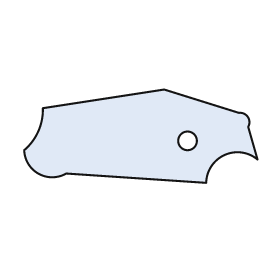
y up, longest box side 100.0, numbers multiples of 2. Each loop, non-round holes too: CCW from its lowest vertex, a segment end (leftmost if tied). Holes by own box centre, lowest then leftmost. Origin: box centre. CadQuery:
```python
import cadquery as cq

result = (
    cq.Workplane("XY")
    .moveTo(28.0, -20.0)
    .threePointArc((36.0, -8.0), (50.0, -10.0))
    .lineTo(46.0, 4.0)
    .threePointArc((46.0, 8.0), (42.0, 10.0))
    .lineTo(10.0, 20.0)
    .lineTo(-42.0, 12.0)
    .threePointArc((-44.0, 2.0), (-50.0, -6.0))
    .threePointArc((-44.0, -16.0), (-32.0, -16.0))
    .close()
    .moveTo(20.0, -2.0)
    .circle(4.0)
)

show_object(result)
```